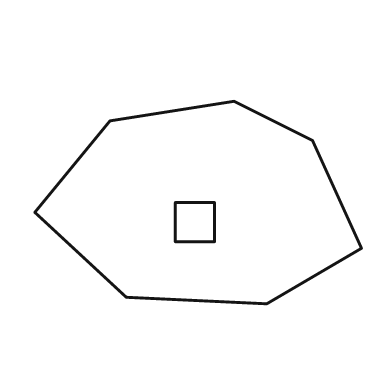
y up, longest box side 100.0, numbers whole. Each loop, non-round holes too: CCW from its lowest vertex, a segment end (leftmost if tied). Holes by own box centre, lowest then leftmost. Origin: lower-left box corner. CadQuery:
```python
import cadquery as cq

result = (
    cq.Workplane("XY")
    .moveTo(71.0, 0.0)
    .lineTo(100.0, 17.0)
    .lineTo(85.0, 50.0)
    .lineTo(61.0, 62.0)
    .lineTo(23.0, 56.0)
    .lineTo(0.0, 28.0)
    .lineTo(28.0, 2.0)
    .close()
    .moveTo(43.0, 19.0)
    .lineTo(55.0, 19.0)
    .lineTo(55.0, 31.0)
    .lineTo(43.0, 31.0)
    .close()
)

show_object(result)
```